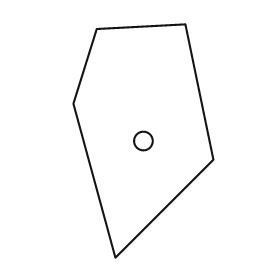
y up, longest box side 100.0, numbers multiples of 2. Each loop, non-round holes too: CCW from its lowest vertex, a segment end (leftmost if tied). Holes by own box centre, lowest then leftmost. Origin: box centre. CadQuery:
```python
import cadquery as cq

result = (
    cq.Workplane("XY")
    .moveTo(-12.0, -50.0)
    .lineTo(30.0, -8.0)
    .lineTo(18.0, 50.0)
    .lineTo(-20.0, 48.0)
    .lineTo(-30.0, 16.0)
    .close()
    .moveTo(0.0, 0.0)
    .circle(4.0)
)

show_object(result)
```